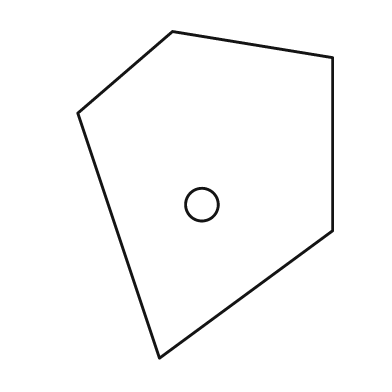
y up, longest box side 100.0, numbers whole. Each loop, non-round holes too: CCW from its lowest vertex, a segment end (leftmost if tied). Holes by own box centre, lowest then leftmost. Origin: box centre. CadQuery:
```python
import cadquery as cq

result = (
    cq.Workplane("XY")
    .moveTo(-14.0, -50.0)
    .lineTo(39.0, -11.0)
    .lineTo(39.0, 42.0)
    .lineTo(-10.0, 50.0)
    .lineTo(-39.0, 25.0)
    .close()
    .moveTo(-1.0, -3.0)
    .circle(5.0)
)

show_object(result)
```